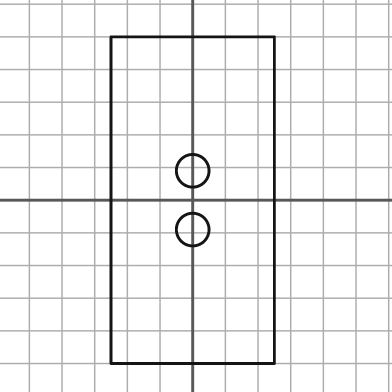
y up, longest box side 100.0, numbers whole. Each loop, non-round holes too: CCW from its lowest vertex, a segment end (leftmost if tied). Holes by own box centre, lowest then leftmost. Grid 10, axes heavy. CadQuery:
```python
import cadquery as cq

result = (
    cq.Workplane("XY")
    .moveTo(-25.0, -50.0)
    .lineTo(25.0, -50.0)
    .lineTo(25.0, 50.0)
    .lineTo(-25.0, 50.0)
    .close()
    .moveTo(0.0, -9.0)
    .circle(5.0)
    .moveTo(0.0, 9.0)
    .circle(5.0)
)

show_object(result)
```